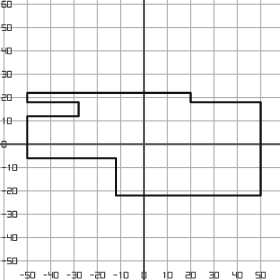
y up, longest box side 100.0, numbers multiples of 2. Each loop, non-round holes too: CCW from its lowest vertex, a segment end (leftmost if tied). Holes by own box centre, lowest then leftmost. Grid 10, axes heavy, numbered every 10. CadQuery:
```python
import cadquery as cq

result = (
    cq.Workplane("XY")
    .moveTo(-12.0, -22.0)
    .lineTo(50.0, -22.0)
    .lineTo(50.0, 18.0)
    .lineTo(20.0, 18.0)
    .lineTo(20.0, 22.0)
    .lineTo(-50.0, 22.0)
    .lineTo(-50.0, 18.0)
    .lineTo(-28.0, 18.0)
    .lineTo(-28.0, 12.0)
    .lineTo(-50.0, 12.0)
    .lineTo(-50.0, -6.0)
    .lineTo(-12.0, -6.0)
    .close()
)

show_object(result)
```